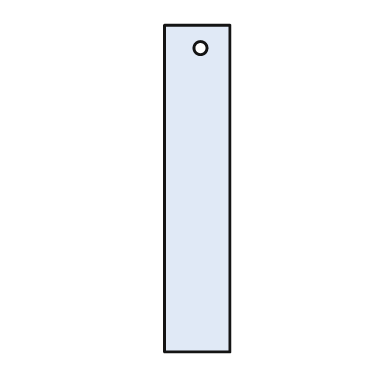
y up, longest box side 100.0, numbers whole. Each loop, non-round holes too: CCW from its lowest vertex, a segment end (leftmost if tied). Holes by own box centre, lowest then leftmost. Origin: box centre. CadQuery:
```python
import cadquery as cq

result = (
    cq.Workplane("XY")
    .moveTo(-10.0, -50.0)
    .lineTo(10.0, -50.0)
    .lineTo(10.0, 50.0)
    .lineTo(-10.0, 50.0)
    .close()
    .moveTo(1.0, 43.0)
    .circle(2.0)
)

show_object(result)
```